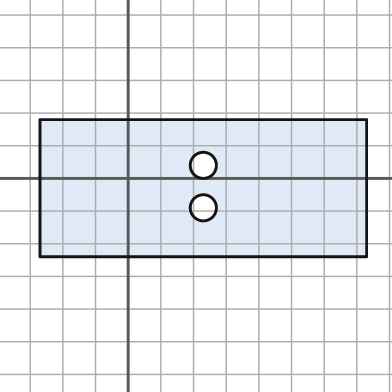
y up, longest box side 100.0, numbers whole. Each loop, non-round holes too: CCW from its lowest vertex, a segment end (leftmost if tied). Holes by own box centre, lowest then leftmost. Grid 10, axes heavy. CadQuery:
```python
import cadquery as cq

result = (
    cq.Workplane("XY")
    .moveTo(-27.0, -24.0)
    .lineTo(73.0, -24.0)
    .lineTo(73.0, 18.0)
    .lineTo(-27.0, 18.0)
    .close()
    .moveTo(23.0, -9.0)
    .circle(4.0)
    .moveTo(23.0, 4.0)
    .circle(4.0)
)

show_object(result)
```